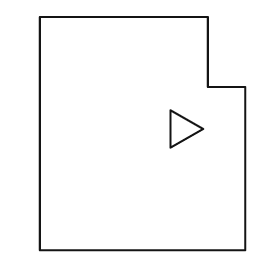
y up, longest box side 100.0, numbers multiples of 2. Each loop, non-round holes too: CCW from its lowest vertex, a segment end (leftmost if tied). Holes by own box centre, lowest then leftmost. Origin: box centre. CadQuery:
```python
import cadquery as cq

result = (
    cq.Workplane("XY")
    .moveTo(-44.0, -50.0)
    .lineTo(44.0, -50.0)
    .lineTo(44.0, 20.0)
    .lineTo(28.0, 20.0)
    .lineTo(28.0, 50.0)
    .lineTo(-44.0, 50.0)
    .close()
    .moveTo(12.0, -6.0)
    .lineTo(26.0, 2.0)
    .lineTo(12.0, 10.0)
    .close()
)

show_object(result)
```